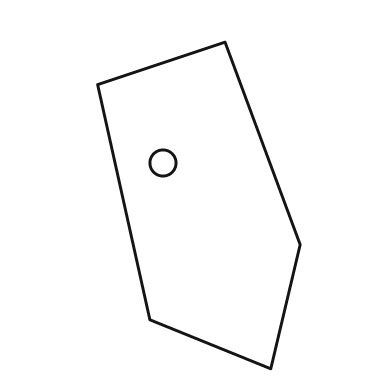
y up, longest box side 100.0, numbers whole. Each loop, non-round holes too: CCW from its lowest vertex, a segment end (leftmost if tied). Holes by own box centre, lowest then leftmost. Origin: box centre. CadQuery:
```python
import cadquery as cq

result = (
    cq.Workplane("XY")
    .moveTo(22.0, -50.0)
    .lineTo(31.0, -12.0)
    .lineTo(8.0, 50.0)
    .lineTo(-31.0, 37.0)
    .lineTo(-15.0, -35.0)
    .close()
    .moveTo(-11.0, 13.0)
    .circle(4.0)
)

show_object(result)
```